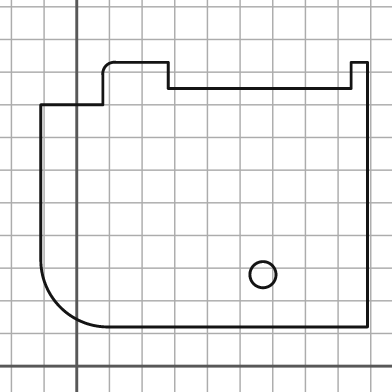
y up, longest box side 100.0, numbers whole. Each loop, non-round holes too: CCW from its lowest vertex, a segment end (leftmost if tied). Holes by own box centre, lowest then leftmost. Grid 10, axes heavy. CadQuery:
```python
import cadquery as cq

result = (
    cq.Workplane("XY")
    .moveTo(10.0, 12.0)
    .lineTo(89.0, 12.0)
    .lineTo(89.0, 93.0)
    .lineTo(84.0, 93.0)
    .lineTo(84.0, 85.0)
    .lineTo(28.0, 85.0)
    .lineTo(28.0, 93.0)
    .lineTo(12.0, 93.0)
    .threePointArc((9.0, 92.0), (8.0, 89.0))
    .lineTo(8.0, 80.0)
    .lineTo(-11.0, 80.0)
    .lineTo(-11.0, 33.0)
    .threePointArc((-5.0, 18.0), (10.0, 12.0))
    .close()
    .moveTo(57.0, 28.0)
    .circle(4.0)
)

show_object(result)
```